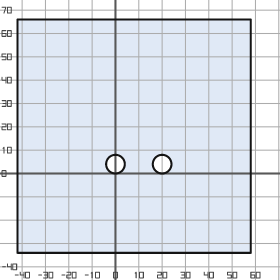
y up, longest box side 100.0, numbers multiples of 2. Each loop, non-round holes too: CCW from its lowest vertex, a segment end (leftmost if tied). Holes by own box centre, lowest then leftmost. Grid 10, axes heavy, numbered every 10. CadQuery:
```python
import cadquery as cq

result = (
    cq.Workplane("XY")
    .moveTo(-42.0, -34.0)
    .lineTo(58.0, -34.0)
    .lineTo(58.0, 66.0)
    .lineTo(-42.0, 66.0)
    .close()
    .moveTo(0.0, 4.0)
    .circle(4.0)
    .moveTo(20.0, 4.0)
    .circle(4.0)
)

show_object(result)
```